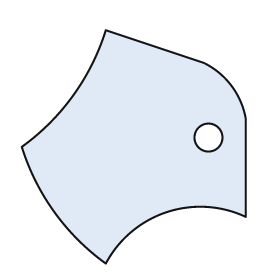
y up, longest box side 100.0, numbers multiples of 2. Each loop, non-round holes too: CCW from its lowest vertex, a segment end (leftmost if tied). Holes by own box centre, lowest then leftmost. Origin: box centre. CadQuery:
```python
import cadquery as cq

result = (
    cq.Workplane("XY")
    .moveTo(-12.0, -50.0)
    .threePointArc((14.0, -28.0), (48.0, -30.0))
    .lineTo(48.0, 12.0)
    .threePointArc((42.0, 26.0), (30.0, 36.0))
    .lineTo(-12.0, 50.0)
    .threePointArc((-26.0, 22.0), (-48.0, 0.0))
    .threePointArc((-34.0, -28.0), (-12.0, -50.0))
    .close()
    .moveTo(32.0, 4.0)
    .circle(6.0)
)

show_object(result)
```